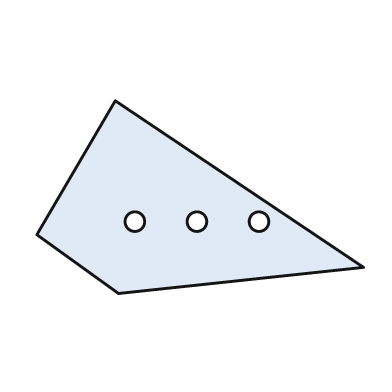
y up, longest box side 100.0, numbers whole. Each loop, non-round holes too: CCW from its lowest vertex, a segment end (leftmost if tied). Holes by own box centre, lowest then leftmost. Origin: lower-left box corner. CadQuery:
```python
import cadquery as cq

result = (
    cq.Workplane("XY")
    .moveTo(25.0, 0.0)
    .lineTo(100.0, 8.0)
    .lineTo(24.0, 59.0)
    .lineTo(0.0, 18.0)
    .close()
    .moveTo(30.0, 22.0)
    .circle(3.0)
    .moveTo(49.0, 22.0)
    .circle(3.0)
    .moveTo(68.0, 22.0)
    .circle(3.0)
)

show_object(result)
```